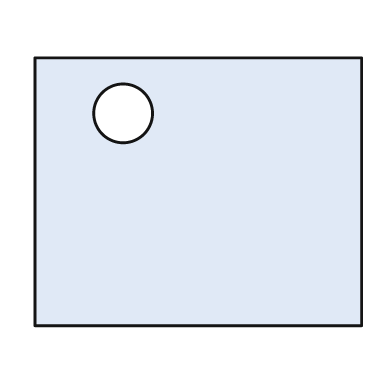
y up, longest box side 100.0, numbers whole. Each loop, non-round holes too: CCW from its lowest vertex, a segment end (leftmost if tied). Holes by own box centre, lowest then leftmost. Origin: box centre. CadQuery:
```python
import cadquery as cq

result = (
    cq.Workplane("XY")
    .moveTo(-50.0, -41.0)
    .lineTo(50.0, -41.0)
    .lineTo(50.0, 41.0)
    .lineTo(-50.0, 41.0)
    .close()
    .moveTo(-23.0, 24.0)
    .circle(9.0)
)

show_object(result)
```